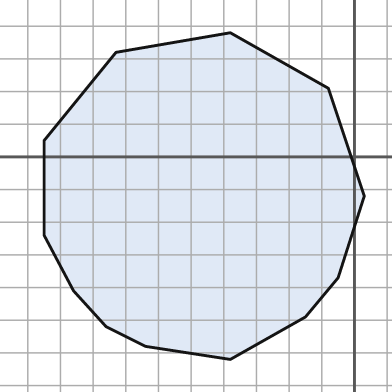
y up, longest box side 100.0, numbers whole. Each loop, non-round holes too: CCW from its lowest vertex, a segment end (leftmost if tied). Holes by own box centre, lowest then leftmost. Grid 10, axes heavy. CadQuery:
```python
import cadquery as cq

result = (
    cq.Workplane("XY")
    .moveTo(-38.0, -62.0)
    .lineTo(-15.0, -49.0)
    .lineTo(-5.0, -37.0)
    .lineTo(3.0, -12.0)
    .lineTo(-8.0, 21.0)
    .lineTo(-38.0, 38.0)
    .lineTo(-73.0, 32.0)
    .lineTo(-95.0, 5.0)
    .lineTo(-95.0, -24.0)
    .lineTo(-86.0, -41.0)
    .lineTo(-76.0, -52.0)
    .lineTo(-64.0, -58.0)
    .close()
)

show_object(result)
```